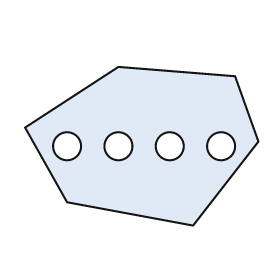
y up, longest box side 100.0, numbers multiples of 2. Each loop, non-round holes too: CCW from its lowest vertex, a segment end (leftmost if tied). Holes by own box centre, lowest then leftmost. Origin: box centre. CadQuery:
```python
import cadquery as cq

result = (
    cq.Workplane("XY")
    .moveTo(22.0, -34.0)
    .lineTo(50.0, 2.0)
    .lineTo(40.0, 30.0)
    .lineTo(-10.0, 34.0)
    .lineTo(-50.0, 8.0)
    .lineTo(-32.0, -24.0)
    .close()
    .moveTo(-32.0, 0.0)
    .circle(6.0)
    .moveTo(-10.0, 0.0)
    .circle(6.0)
    .moveTo(12.0, 0.0)
    .circle(6.0)
    .moveTo(34.0, 0.0)
    .circle(6.0)
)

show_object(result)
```